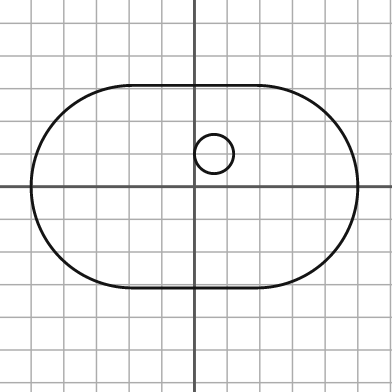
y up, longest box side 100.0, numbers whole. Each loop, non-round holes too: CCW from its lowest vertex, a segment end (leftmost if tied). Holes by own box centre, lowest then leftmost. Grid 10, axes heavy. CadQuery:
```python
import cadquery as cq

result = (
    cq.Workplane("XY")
    .moveTo(-19.0, -31.0)
    .lineTo(19.0, -31.0)
    .threePointArc((50.0, 0.0), (19.0, 31.0))
    .lineTo(-19.0, 31.0)
    .threePointArc((-50.0, 0.0), (-19.0, -31.0))
    .close()
    .moveTo(6.0, 10.0)
    .circle(6.0)
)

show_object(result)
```